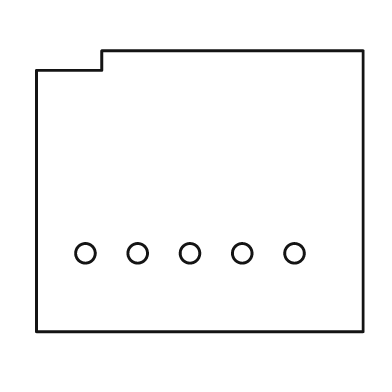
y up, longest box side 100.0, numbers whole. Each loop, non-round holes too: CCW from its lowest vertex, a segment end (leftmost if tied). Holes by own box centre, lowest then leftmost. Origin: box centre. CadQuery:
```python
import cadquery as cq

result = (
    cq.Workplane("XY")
    .moveTo(-50.0, -43.0)
    .lineTo(50.0, -43.0)
    .lineTo(50.0, 43.0)
    .lineTo(-30.0, 43.0)
    .lineTo(-30.0, 37.0)
    .lineTo(-50.0, 37.0)
    .close()
    .moveTo(-35.0, -19.0)
    .circle(3.0)
    .moveTo(-19.0, -19.0)
    .circle(3.0)
    .moveTo(-3.0, -19.0)
    .circle(3.0)
    .moveTo(13.0, -19.0)
    .circle(3.0)
    .moveTo(29.0, -19.0)
    .circle(3.0)
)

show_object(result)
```